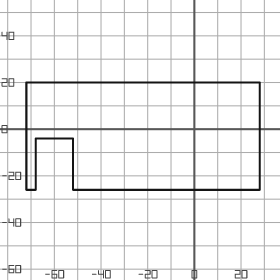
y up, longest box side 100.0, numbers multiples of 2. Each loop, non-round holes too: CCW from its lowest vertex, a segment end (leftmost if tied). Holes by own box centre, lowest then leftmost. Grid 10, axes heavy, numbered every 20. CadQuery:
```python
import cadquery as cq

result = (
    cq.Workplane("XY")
    .moveTo(-72.0, -26.0)
    .lineTo(-68.0, -26.0)
    .lineTo(-68.0, -4.0)
    .lineTo(-52.0, -4.0)
    .lineTo(-52.0, -26.0)
    .lineTo(28.0, -26.0)
    .lineTo(28.0, 20.0)
    .lineTo(-72.0, 20.0)
    .close()
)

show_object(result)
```